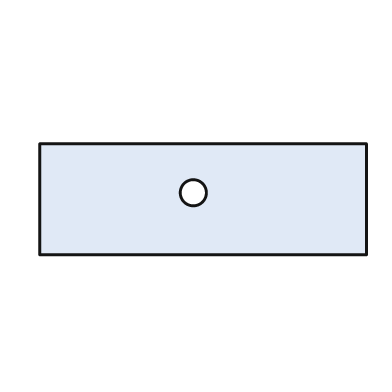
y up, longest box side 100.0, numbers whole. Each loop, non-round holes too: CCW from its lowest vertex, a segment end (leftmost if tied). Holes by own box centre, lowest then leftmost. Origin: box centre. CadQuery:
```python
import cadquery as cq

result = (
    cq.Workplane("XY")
    .moveTo(-50.0, -17.0)
    .lineTo(50.0, -17.0)
    .lineTo(50.0, 17.0)
    .lineTo(-50.0, 17.0)
    .close()
    .moveTo(-3.0, 2.0)
    .circle(4.0)
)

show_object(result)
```